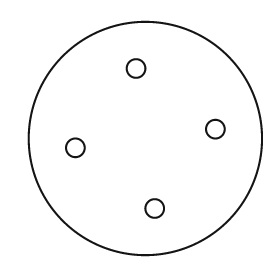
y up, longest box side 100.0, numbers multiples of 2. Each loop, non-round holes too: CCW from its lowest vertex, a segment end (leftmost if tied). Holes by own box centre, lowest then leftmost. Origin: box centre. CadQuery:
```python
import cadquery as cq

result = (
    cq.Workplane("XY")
    .moveTo(0.0, 0.0)
    .circle(50.0)
    .moveTo(4.0, -30.0)
    .circle(4.0)
    .moveTo(-30.0, -4.0)
    .circle(4.0)
    .moveTo(30.0, 4.0)
    .circle(4.0)
    .moveTo(-4.0, 30.0)
    .circle(4.0)
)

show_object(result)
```